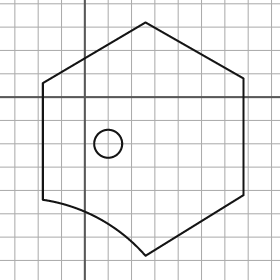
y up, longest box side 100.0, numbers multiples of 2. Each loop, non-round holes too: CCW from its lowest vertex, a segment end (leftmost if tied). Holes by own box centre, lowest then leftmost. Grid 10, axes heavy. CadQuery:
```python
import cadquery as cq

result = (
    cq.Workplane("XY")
    .moveTo(26.0, -68.0)
    .lineTo(68.0, -42.0)
    .lineTo(68.0, 8.0)
    .lineTo(26.0, 32.0)
    .lineTo(-18.0, 6.0)
    .lineTo(-18.0, -44.0)
    .threePointArc((6.0, -52.0), (26.0, -68.0))
    .close()
    .moveTo(10.0, -20.0)
    .circle(6.0)
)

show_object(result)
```